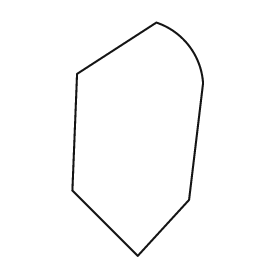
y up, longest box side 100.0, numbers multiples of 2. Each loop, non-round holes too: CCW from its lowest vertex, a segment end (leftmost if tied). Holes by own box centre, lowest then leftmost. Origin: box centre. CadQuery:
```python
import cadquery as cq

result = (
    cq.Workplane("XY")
    .moveTo(0.0, -50.0)
    .lineTo(22.0, -26.0)
    .lineTo(28.0, 24.0)
    .threePointArc((22.0, 40.0), (8.0, 50.0))
    .lineTo(-26.0, 28.0)
    .lineTo(-28.0, -22.0)
    .close()
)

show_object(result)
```